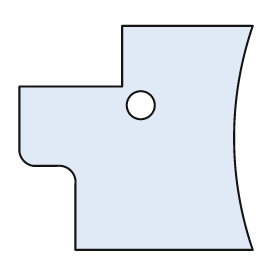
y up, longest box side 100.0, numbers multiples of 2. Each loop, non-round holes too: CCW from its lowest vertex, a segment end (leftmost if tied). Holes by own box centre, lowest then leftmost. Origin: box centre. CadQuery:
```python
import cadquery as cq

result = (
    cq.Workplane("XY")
    .moveTo(-26.0, -48.0)
    .lineTo(50.0, -48.0)
    .threePointArc((42.0, 0.0), (50.0, 48.0))
    .lineTo(-6.0, 48.0)
    .lineTo(-6.0, 22.0)
    .lineTo(-50.0, 22.0)
    .lineTo(-50.0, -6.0)
    .threePointArc((-48.0, -10.0), (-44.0, -12.0))
    .lineTo(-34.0, -12.0)
    .threePointArc((-28.0, -14.0), (-26.0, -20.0))
    .close()
    .moveTo(2.0, 14.0)
    .circle(6.0)
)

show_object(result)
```